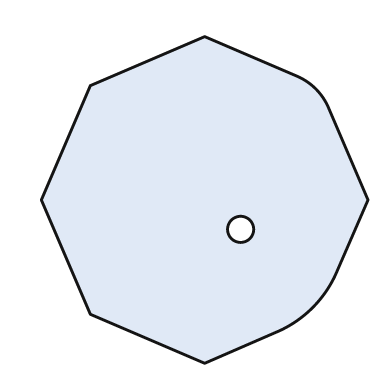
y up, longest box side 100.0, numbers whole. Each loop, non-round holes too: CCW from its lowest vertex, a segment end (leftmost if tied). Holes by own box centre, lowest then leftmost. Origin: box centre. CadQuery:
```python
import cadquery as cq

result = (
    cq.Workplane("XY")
    .moveTo(0.0, -50.0)
    .lineTo(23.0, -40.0)
    .threePointArc((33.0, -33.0), (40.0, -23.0))
    .lineTo(50.0, 0.0)
    .lineTo(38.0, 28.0)
    .threePointArc((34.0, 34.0), (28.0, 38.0))
    .lineTo(0.0, 50.0)
    .lineTo(-35.0, 35.0)
    .lineTo(-50.0, 0.0)
    .lineTo(-35.0, -35.0)
    .close()
    .moveTo(11.0, -9.0)
    .circle(4.0)
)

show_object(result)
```